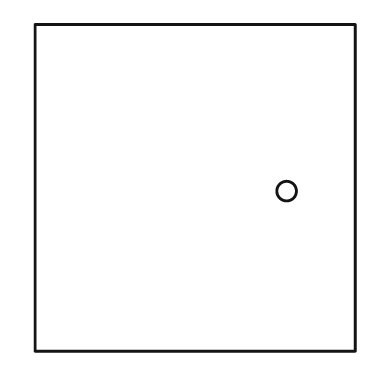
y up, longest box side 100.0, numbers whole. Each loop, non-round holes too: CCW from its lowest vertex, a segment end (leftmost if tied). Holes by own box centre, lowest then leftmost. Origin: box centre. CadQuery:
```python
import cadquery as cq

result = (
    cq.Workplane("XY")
    .moveTo(-49.0, -50.0)
    .lineTo(49.0, -50.0)
    .lineTo(49.0, 50.0)
    .lineTo(-49.0, 50.0)
    .close()
    .moveTo(28.0, -1.0)
    .circle(3.0)
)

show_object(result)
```